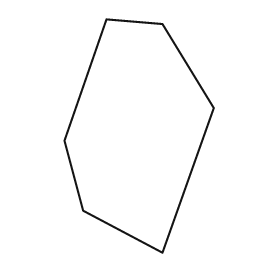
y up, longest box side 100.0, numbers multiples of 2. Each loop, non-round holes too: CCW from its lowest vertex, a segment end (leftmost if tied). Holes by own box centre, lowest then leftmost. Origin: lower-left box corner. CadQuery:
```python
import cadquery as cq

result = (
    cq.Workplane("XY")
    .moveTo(42.0, 0.0)
    .lineTo(64.0, 62.0)
    .lineTo(42.0, 98.0)
    .lineTo(18.0, 100.0)
    .lineTo(0.0, 48.0)
    .lineTo(8.0, 18.0)
    .close()
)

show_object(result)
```